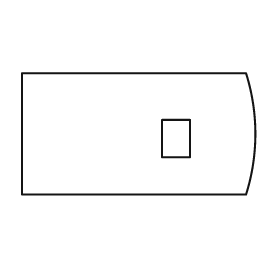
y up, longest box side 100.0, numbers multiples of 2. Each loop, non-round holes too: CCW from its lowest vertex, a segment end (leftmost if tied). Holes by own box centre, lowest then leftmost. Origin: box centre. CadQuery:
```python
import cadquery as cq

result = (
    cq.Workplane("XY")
    .moveTo(-50.0, -26.0)
    .lineTo(46.0, -26.0)
    .threePointArc((50.0, 0.0), (46.0, 26.0))
    .lineTo(-50.0, 26.0)
    .close()
    .moveTo(10.0, -10.0)
    .lineTo(22.0, -10.0)
    .lineTo(22.0, 6.0)
    .lineTo(10.0, 6.0)
    .close()
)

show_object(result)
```